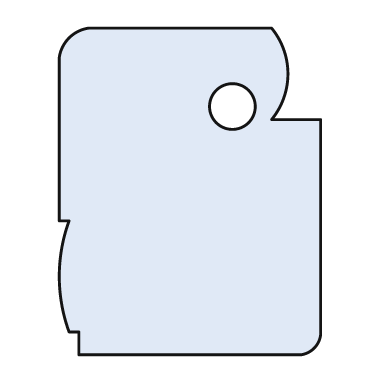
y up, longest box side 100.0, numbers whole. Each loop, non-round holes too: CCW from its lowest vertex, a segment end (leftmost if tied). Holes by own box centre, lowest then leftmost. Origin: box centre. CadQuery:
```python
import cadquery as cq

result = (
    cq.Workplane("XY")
    .moveTo(-34.0, -50.0)
    .lineTo(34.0, -50.0)
    .threePointArc((38.0, -48.0), (40.0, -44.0))
    .lineTo(40.0, 22.0)
    .lineTo(25.0, 22.0)
    .threePointArc((30.0, 36.0), (25.0, 50.0))
    .lineTo(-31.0, 50.0)
    .threePointArc((-37.0, 47.0), (-40.0, 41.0))
    .lineTo(-40.0, -9.0)
    .lineTo(-37.0, -9.0)
    .threePointArc((-40.0, -26.0), (-37.0, -43.0))
    .lineTo(-34.0, -43.0)
    .close()
    .moveTo(13.0, 26.0)
    .circle(7.0)
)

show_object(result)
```